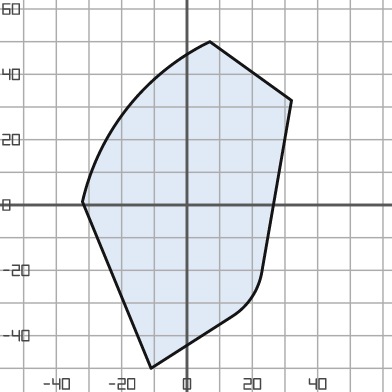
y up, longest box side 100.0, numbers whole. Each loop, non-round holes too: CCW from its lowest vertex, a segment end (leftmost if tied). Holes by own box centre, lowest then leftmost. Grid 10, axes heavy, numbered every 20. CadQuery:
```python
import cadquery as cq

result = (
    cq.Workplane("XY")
    .moveTo(-11.0, -50.0)
    .lineTo(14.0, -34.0)
    .threePointArc((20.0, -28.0), (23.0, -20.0))
    .lineTo(32.0, 32.0)
    .lineTo(7.0, 50.0)
    .threePointArc((-18.0, 30.0), (-32.0, 1.0))
    .close()
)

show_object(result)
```